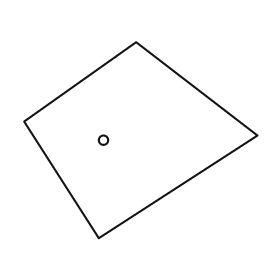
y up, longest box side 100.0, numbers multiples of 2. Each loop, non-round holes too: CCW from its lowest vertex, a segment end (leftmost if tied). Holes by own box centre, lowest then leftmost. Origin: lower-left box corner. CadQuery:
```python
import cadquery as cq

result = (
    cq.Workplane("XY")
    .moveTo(32.0, 0.0)
    .lineTo(100.0, 44.0)
    .lineTo(48.0, 84.0)
    .lineTo(0.0, 50.0)
    .close()
    .moveTo(34.0, 42.0)
    .circle(2.0)
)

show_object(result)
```